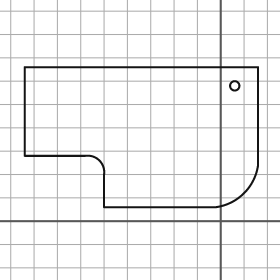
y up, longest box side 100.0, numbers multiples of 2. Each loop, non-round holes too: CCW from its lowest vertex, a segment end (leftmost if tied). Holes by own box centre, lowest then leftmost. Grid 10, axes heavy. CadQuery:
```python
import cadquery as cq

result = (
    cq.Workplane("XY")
    .moveTo(-50.0, 6.0)
    .lineTo(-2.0, 6.0)
    .threePointArc((10.0, 12.0), (16.0, 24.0))
    .lineTo(16.0, 66.0)
    .lineTo(-84.0, 66.0)
    .lineTo(-84.0, 28.0)
    .lineTo(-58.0, 28.0)
    .threePointArc((-52.0, 26.0), (-50.0, 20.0))
    .close()
    .moveTo(6.0, 58.0)
    .circle(2.0)
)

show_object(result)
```